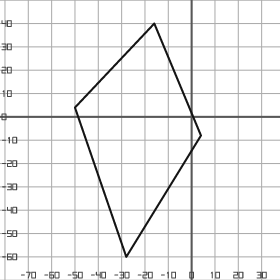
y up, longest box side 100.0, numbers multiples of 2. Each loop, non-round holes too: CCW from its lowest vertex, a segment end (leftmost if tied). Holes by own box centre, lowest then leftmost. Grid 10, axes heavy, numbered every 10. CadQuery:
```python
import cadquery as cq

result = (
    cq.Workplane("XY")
    .moveTo(-28.0, -60.0)
    .lineTo(4.0, -8.0)
    .lineTo(-16.0, 40.0)
    .lineTo(-50.0, 4.0)
    .close()
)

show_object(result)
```